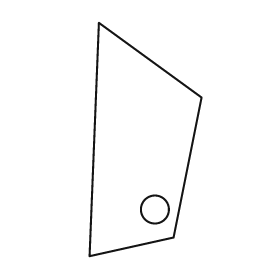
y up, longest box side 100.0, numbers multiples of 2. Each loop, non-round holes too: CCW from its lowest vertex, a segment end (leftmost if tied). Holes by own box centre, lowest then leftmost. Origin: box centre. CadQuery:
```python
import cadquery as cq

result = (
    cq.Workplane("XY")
    .moveTo(-24.0, -50.0)
    .lineTo(12.0, -42.0)
    .lineTo(24.0, 18.0)
    .lineTo(-20.0, 50.0)
    .close()
    .moveTo(4.0, -30.0)
    .circle(6.0)
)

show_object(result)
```